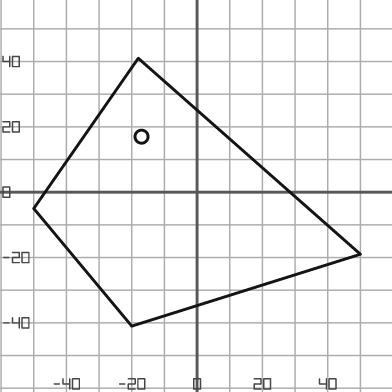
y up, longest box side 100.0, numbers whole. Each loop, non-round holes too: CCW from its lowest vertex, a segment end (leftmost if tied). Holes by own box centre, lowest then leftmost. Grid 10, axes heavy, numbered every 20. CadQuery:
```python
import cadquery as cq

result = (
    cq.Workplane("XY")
    .moveTo(-20.0, -41.0)
    .lineTo(50.0, -19.0)
    .lineTo(-18.0, 41.0)
    .lineTo(-50.0, -5.0)
    .close()
    .moveTo(-17.0, 17.0)
    .circle(2.0)
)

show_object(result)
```